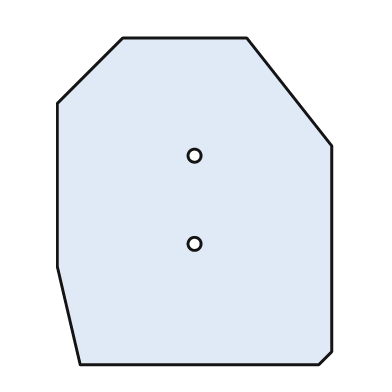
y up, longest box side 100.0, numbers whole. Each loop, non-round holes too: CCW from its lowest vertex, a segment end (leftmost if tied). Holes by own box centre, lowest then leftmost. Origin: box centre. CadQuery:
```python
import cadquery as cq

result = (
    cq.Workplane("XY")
    .moveTo(-35.0, -50.0)
    .lineTo(38.0, -50.0)
    .lineTo(42.0, -46.0)
    .lineTo(42.0, 17.0)
    .lineTo(16.0, 50.0)
    .lineTo(-22.0, 50.0)
    .lineTo(-42.0, 30.0)
    .lineTo(-42.0, -20.0)
    .close()
    .moveTo(0.0, -13.0)
    .circle(2.0)
    .moveTo(0.0, 14.0)
    .circle(2.0)
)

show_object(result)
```